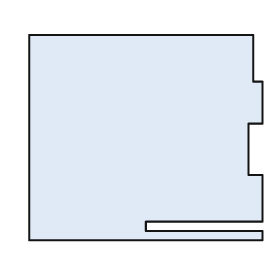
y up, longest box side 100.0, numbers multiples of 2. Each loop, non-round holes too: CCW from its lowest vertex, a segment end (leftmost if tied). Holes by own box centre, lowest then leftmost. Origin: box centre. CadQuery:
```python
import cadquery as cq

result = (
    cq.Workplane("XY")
    .moveTo(-50.0, -44.0)
    .lineTo(50.0, -44.0)
    .lineTo(50.0, -40.0)
    .lineTo(0.0, -40.0)
    .lineTo(0.0, -36.0)
    .lineTo(50.0, -36.0)
    .lineTo(50.0, -16.0)
    .lineTo(44.0, -16.0)
    .lineTo(44.0, 6.0)
    .lineTo(50.0, 6.0)
    .lineTo(50.0, 24.0)
    .lineTo(46.0, 24.0)
    .lineTo(46.0, 44.0)
    .lineTo(-50.0, 44.0)
    .close()
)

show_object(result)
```